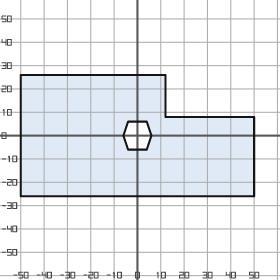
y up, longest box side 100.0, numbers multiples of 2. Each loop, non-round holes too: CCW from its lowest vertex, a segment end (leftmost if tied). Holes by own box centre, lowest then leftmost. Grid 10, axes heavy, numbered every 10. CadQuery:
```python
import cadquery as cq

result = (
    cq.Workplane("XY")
    .moveTo(-50.0, -26.0)
    .lineTo(50.0, -26.0)
    .lineTo(50.0, 8.0)
    .lineTo(12.0, 8.0)
    .lineTo(12.0, 26.0)
    .lineTo(-50.0, 26.0)
    .close()
    .moveTo(-4.0, -6.0)
    .lineTo(4.0, -6.0)
    .lineTo(6.0, 0.0)
    .lineTo(4.0, 6.0)
    .lineTo(-4.0, 6.0)
    .lineTo(-6.0, 0.0)
    .close()
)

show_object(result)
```